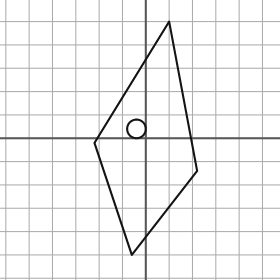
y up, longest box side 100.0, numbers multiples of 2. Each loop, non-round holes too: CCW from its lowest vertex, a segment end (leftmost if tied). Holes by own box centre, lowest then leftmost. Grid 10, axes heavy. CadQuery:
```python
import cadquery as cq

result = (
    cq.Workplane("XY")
    .moveTo(-6.0, -50.0)
    .lineTo(22.0, -14.0)
    .lineTo(10.0, 50.0)
    .lineTo(-22.0, -2.0)
    .close()
    .moveTo(-4.0, 4.0)
    .circle(4.0)
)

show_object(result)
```